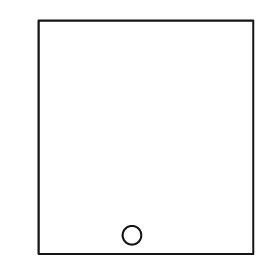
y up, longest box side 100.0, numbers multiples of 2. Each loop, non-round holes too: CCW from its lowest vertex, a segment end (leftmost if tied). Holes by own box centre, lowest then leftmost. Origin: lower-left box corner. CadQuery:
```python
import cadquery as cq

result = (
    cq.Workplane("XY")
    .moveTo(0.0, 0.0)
    .lineTo(92.0, 0.0)
    .lineTo(92.0, 100.0)
    .lineTo(0.0, 100.0)
    .close()
    .moveTo(40.0, 8.0)
    .circle(4.0)
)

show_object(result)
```